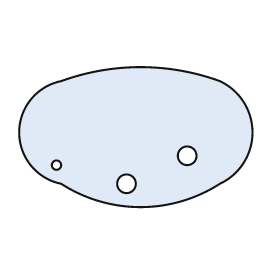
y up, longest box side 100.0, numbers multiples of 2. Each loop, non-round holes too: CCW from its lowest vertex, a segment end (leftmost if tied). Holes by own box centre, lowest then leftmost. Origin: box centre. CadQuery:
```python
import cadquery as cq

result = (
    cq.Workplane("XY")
    .moveTo(-32.0, -20.0)
    .threePointArc((2.0, -30.0), (36.0, -20.0))
    .threePointArc((50.0, 2.0), (36.0, 24.0))
    .threePointArc((2.0, 30.0), (-32.0, 24.0))
    .threePointArc((-50.0, 2.0), (-32.0, -20.0))
    .close()
    .moveTo(-4.0, -20.0)
    .circle(4.0)
    .moveTo(-34.0, -12.0)
    .circle(2.0)
    .moveTo(22.0, -8.0)
    .circle(4.0)
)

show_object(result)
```